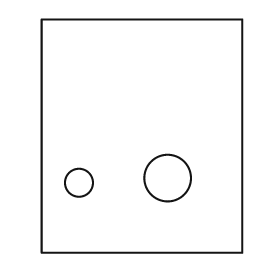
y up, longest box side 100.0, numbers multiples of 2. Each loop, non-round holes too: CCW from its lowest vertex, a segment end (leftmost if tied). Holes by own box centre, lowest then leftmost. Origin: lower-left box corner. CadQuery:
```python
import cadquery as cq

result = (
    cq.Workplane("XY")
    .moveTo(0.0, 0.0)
    .lineTo(86.0, 0.0)
    .lineTo(86.0, 100.0)
    .lineTo(0.0, 100.0)
    .close()
    .moveTo(16.0, 30.0)
    .circle(6.0)
    .moveTo(54.0, 32.0)
    .circle(10.0)
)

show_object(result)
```